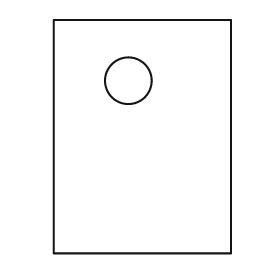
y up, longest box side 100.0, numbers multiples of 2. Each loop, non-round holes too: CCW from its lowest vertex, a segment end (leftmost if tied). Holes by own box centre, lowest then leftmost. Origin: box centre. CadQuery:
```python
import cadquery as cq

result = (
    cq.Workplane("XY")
    .moveTo(-38.0, -50.0)
    .lineTo(38.0, -50.0)
    .lineTo(38.0, 50.0)
    .lineTo(-38.0, 50.0)
    .close()
    .moveTo(-6.0, 24.0)
    .circle(10.0)
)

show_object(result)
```